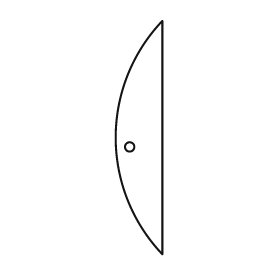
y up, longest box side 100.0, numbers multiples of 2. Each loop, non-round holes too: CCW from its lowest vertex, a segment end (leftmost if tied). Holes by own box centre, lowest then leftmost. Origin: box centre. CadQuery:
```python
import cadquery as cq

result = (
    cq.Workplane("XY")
    .moveTo(10.0, -50.0)
    .lineTo(10.0, 50.0)
    .threePointArc((-10.0, 0.0), (10.0, -50.0))
    .close()
    .moveTo(-4.0, -4.0)
    .circle(2.0)
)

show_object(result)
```